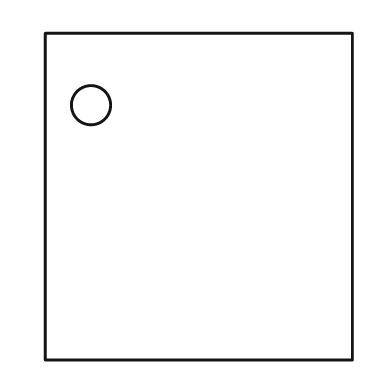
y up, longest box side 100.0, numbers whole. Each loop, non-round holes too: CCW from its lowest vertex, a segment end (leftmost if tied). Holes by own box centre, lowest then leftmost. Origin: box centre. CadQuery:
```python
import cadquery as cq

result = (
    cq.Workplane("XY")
    .moveTo(-47.0, -50.0)
    .lineTo(47.0, -50.0)
    .lineTo(47.0, 50.0)
    .lineTo(-47.0, 50.0)
    .close()
    .moveTo(-33.0, 28.0)
    .circle(6.0)
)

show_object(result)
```